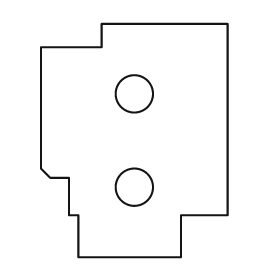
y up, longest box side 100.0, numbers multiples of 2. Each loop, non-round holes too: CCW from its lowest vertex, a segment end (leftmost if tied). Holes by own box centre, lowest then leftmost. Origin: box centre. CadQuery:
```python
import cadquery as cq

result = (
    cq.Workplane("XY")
    .moveTo(-24.0, -50.0)
    .lineTo(20.0, -50.0)
    .lineTo(20.0, -32.0)
    .lineTo(40.0, -32.0)
    .lineTo(40.0, 50.0)
    .lineTo(-14.0, 50.0)
    .lineTo(-14.0, 40.0)
    .lineTo(-40.0, 40.0)
    .lineTo(-40.0, -12.0)
    .lineTo(-36.0, -16.0)
    .lineTo(-28.0, -16.0)
    .lineTo(-28.0, -32.0)
    .lineTo(-24.0, -32.0)
    .close()
    .moveTo(0.0, -20.0)
    .circle(8.0)
    .moveTo(0.0, 20.0)
    .circle(8.0)
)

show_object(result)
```